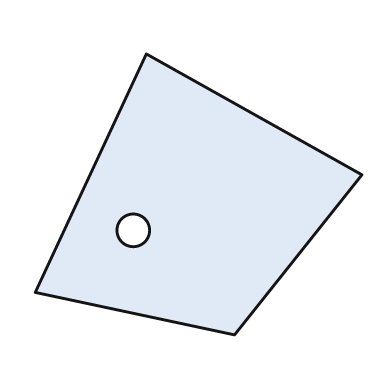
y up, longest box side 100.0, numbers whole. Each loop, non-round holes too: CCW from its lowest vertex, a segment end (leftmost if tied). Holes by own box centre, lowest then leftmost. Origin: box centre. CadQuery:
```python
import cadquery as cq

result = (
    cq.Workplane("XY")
    .moveTo(11.0, -43.0)
    .lineTo(50.0, 6.0)
    .lineTo(-16.0, 43.0)
    .lineTo(-50.0, -30.0)
    .close()
    .moveTo(-20.0, -11.0)
    .circle(5.0)
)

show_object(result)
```